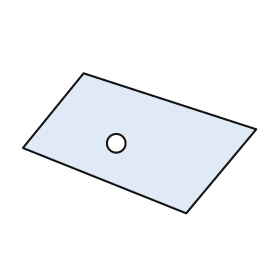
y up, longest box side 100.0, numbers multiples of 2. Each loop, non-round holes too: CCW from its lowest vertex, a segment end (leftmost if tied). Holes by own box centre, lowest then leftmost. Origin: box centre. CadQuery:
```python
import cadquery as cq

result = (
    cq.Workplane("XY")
    .moveTo(20.0, -30.0)
    .lineTo(50.0, 6.0)
    .lineTo(-24.0, 30.0)
    .lineTo(-50.0, -2.0)
    .close()
    .moveTo(-10.0, 0.0)
    .circle(4.0)
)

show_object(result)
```